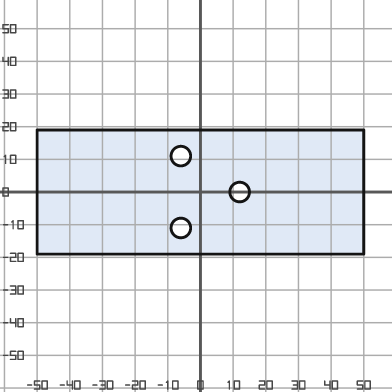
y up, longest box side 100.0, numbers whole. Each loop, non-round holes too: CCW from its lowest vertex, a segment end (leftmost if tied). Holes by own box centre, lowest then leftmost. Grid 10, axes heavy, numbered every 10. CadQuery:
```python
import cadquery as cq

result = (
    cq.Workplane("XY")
    .moveTo(-50.0, -19.0)
    .lineTo(50.0, -19.0)
    .lineTo(50.0, 19.0)
    .lineTo(-50.0, 19.0)
    .close()
    .moveTo(-6.0, -11.0)
    .circle(3.0)
    .moveTo(12.0, 0.0)
    .circle(3.0)
    .moveTo(-6.0, 11.0)
    .circle(3.0)
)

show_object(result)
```